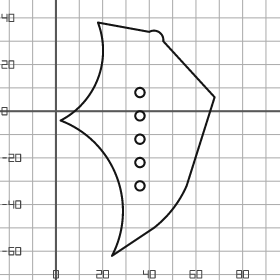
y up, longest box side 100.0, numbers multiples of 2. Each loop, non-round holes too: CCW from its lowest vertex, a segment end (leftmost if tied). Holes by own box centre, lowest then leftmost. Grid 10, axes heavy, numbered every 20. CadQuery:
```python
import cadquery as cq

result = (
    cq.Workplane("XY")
    .moveTo(24.0, -62.0)
    .lineTo(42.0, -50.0)
    .threePointArc((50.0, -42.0), (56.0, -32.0))
    .lineTo(68.0, 6.0)
    .lineTo(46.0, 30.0)
    .threePointArc((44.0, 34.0), (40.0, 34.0))
    .lineTo(18.0, 38.0)
    .threePointArc((18.0, 14.0), (2.0, -4.0))
    .threePointArc((26.0, -28.0), (24.0, -62.0))
    .close()
    .moveTo(36.0, -32.0)
    .circle(2.0)
    .moveTo(36.0, -22.0)
    .circle(2.0)
    .moveTo(36.0, -12.0)
    .circle(2.0)
    .moveTo(36.0, -2.0)
    .circle(2.0)
    .moveTo(36.0, 8.0)
    .circle(2.0)
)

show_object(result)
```